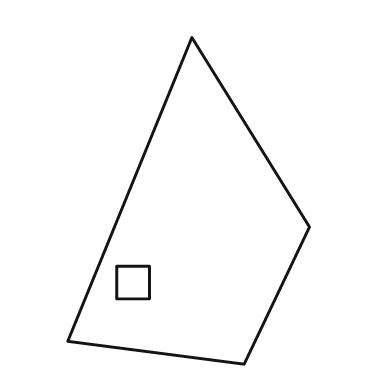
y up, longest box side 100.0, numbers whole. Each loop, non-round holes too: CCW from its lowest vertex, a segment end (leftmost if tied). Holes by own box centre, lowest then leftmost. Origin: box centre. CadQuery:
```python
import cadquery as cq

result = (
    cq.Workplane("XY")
    .moveTo(17.0, -50.0)
    .lineTo(37.0, -8.0)
    .lineTo(1.0, 50.0)
    .lineTo(-37.0, -43.0)
    .close()
    .moveTo(-22.0, -30.0)
    .lineTo(-12.0, -30.0)
    .lineTo(-12.0, -20.0)
    .lineTo(-22.0, -20.0)
    .close()
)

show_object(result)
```